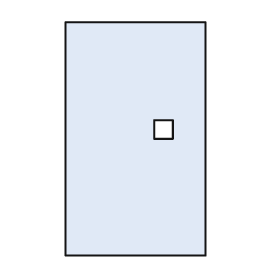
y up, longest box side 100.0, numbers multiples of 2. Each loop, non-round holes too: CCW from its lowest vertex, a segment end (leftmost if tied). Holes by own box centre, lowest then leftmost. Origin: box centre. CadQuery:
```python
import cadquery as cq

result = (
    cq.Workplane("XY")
    .moveTo(-30.0, -50.0)
    .lineTo(30.0, -50.0)
    .lineTo(30.0, 50.0)
    .lineTo(-30.0, 50.0)
    .close()
    .moveTo(8.0, 0.0)
    .lineTo(16.0, 0.0)
    .lineTo(16.0, 8.0)
    .lineTo(8.0, 8.0)
    .close()
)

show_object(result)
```